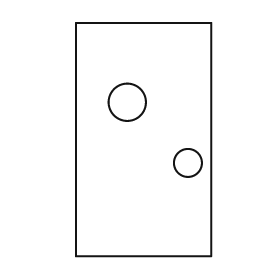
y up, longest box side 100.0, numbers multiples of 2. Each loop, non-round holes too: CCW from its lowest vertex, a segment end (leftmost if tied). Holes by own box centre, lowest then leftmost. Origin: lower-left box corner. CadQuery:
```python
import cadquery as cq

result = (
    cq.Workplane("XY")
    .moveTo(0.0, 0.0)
    .lineTo(58.0, 0.0)
    .lineTo(58.0, 100.0)
    .lineTo(0.0, 100.0)
    .close()
    .moveTo(48.0, 40.0)
    .circle(6.0)
    .moveTo(22.0, 66.0)
    .circle(8.0)
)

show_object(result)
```